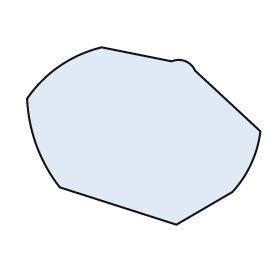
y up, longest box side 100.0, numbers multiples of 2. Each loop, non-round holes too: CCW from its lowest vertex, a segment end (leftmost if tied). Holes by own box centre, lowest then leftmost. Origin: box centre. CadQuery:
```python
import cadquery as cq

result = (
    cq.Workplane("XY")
    .moveTo(14.0, -38.0)
    .lineTo(38.0, -24.0)
    .threePointArc((46.0, -12.0), (50.0, 2.0))
    .lineTo(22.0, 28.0)
    .threePointArc((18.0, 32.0), (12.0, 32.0))
    .lineTo(-18.0, 38.0)
    .threePointArc((-36.0, 30.0), (-50.0, 16.0))
    .threePointArc((-46.0, -4.0), (-36.0, -22.0))
    .close()
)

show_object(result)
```